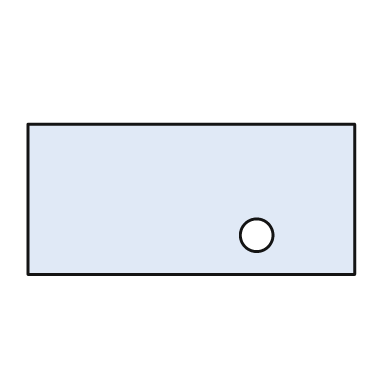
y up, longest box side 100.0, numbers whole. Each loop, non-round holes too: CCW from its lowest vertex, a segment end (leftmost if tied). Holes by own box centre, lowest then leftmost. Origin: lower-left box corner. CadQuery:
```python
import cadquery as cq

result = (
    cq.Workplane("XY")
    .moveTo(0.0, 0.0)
    .lineTo(100.0, 0.0)
    .lineTo(100.0, 46.0)
    .lineTo(0.0, 46.0)
    .close()
    .moveTo(70.0, 12.0)
    .circle(5.0)
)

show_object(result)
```